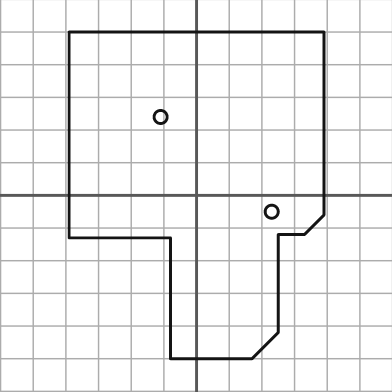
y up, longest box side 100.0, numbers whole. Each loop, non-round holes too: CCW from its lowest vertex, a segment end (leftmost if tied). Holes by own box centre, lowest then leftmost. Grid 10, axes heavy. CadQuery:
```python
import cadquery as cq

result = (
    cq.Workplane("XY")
    .moveTo(-8.0, -50.0)
    .lineTo(17.0, -50.0)
    .lineTo(25.0, -42.0)
    .lineTo(25.0, -12.0)
    .lineTo(33.0, -12.0)
    .lineTo(39.0, -6.0)
    .lineTo(39.0, 50.0)
    .lineTo(-39.0, 50.0)
    .lineTo(-39.0, -13.0)
    .lineTo(-8.0, -13.0)
    .close()
    .moveTo(23.0, -5.0)
    .circle(2.0)
    .moveTo(-11.0, 24.0)
    .circle(2.0)
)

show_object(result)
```